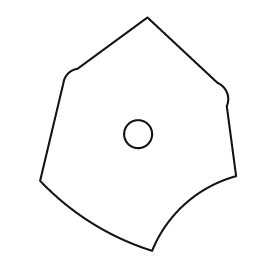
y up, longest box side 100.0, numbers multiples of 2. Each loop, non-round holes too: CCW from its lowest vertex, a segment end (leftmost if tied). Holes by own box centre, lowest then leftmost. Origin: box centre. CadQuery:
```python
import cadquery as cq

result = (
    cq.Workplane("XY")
    .moveTo(6.0, -50.0)
    .threePointArc((20.0, -30.0), (42.0, -18.0))
    .lineTo(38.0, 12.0)
    .threePointArc((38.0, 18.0), (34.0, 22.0))
    .lineTo(4.0, 50.0)
    .lineTo(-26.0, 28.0)
    .threePointArc((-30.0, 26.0), (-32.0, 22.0))
    .lineTo(-42.0, -20.0)
    .threePointArc((-20.0, -38.0), (6.0, -50.0))
    .close()
    .moveTo(0.0, 0.0)
    .circle(6.0)
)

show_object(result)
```